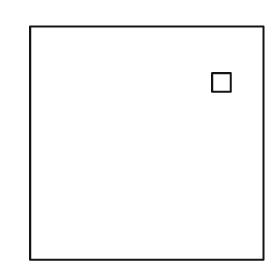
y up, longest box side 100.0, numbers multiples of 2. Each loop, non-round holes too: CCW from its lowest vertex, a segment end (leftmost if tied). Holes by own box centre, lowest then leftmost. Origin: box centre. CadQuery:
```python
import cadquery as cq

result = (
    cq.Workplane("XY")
    .moveTo(-50.0, -50.0)
    .lineTo(50.0, -50.0)
    .lineTo(50.0, 50.0)
    .lineTo(-50.0, 50.0)
    .close()
    .moveTo(28.0, 22.0)
    .lineTo(36.0, 22.0)
    .lineTo(36.0, 30.0)
    .lineTo(28.0, 30.0)
    .close()
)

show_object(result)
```